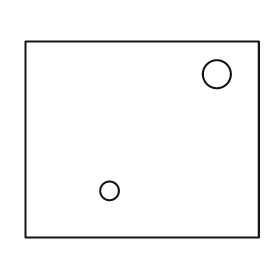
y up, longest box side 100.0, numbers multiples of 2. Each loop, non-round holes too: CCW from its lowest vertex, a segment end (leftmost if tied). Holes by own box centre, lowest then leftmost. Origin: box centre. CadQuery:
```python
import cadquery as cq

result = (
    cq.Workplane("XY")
    .moveTo(-50.0, -42.0)
    .lineTo(50.0, -42.0)
    .lineTo(50.0, 42.0)
    .lineTo(-50.0, 42.0)
    .close()
    .moveTo(-14.0, -22.0)
    .circle(4.0)
    .moveTo(32.0, 28.0)
    .circle(6.0)
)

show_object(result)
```